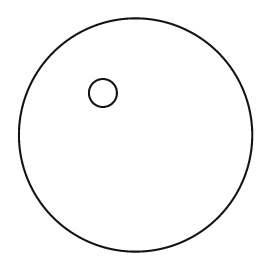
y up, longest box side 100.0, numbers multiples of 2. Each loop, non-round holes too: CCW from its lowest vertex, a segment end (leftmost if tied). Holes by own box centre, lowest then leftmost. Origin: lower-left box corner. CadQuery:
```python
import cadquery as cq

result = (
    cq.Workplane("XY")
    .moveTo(50.0, 50.0)
    .circle(50.0)
    .moveTo(36.0, 68.0)
    .circle(6.0)
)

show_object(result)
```